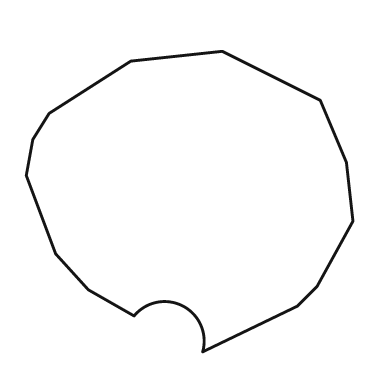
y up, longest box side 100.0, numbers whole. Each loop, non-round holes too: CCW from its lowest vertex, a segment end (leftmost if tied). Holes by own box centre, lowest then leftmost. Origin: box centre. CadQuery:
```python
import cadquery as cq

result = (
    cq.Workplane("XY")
    .moveTo(4.0, -46.0)
    .lineTo(33.0, -32.0)
    .lineTo(39.0, -26.0)
    .lineTo(50.0, -6.0)
    .lineTo(48.0, 12.0)
    .lineTo(40.0, 31.0)
    .lineTo(10.0, 46.0)
    .lineTo(-18.0, 43.0)
    .lineTo(-43.0, 27.0)
    .lineTo(-48.0, 19.0)
    .lineTo(-50.0, 8.0)
    .lineTo(-41.0, -16.0)
    .lineTo(-31.0, -27.0)
    .lineTo(-17.0, -35.0)
    .threePointArc((-2.0, -32.0), (4.0, -46.0))
    .close()
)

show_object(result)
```